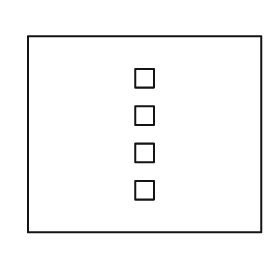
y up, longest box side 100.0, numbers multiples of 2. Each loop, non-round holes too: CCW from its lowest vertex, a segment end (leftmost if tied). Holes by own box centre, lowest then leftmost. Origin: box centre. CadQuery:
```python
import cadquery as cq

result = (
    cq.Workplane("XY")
    .moveTo(-50.0, -42.0)
    .lineTo(50.0, -42.0)
    .lineTo(50.0, 42.0)
    .lineTo(-50.0, 42.0)
    .close()
    .moveTo(-4.0, -28.0)
    .lineTo(4.0, -28.0)
    .lineTo(4.0, -20.0)
    .lineTo(-4.0, -20.0)
    .close()
    .moveTo(-4.0, -12.0)
    .lineTo(4.0, -12.0)
    .lineTo(4.0, -4.0)
    .lineTo(-4.0, -4.0)
    .close()
    .moveTo(-4.0, 4.0)
    .lineTo(4.0, 4.0)
    .lineTo(4.0, 12.0)
    .lineTo(-4.0, 12.0)
    .close()
    .moveTo(-4.0, 20.0)
    .lineTo(4.0, 20.0)
    .lineTo(4.0, 28.0)
    .lineTo(-4.0, 28.0)
    .close()
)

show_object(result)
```